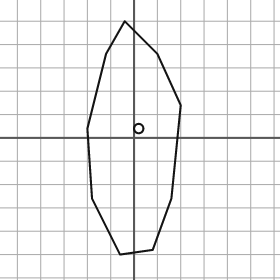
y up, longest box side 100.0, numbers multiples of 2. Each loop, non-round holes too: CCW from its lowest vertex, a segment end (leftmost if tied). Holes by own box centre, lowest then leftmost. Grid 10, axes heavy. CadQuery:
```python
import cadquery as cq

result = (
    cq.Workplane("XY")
    .moveTo(-6.0, -50.0)
    .lineTo(8.0, -48.0)
    .lineTo(16.0, -26.0)
    .lineTo(20.0, 14.0)
    .lineTo(10.0, 36.0)
    .lineTo(-4.0, 50.0)
    .lineTo(-12.0, 36.0)
    .lineTo(-20.0, 4.0)
    .lineTo(-18.0, -26.0)
    .close()
    .moveTo(2.0, 4.0)
    .circle(2.0)
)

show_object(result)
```